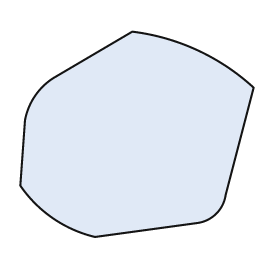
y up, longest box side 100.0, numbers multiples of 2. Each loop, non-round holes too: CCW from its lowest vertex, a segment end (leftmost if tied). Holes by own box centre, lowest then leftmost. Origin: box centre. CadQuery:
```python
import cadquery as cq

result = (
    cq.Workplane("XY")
    .moveTo(-18.0, -44.0)
    .lineTo(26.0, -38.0)
    .threePointArc((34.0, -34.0), (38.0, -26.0))
    .lineTo(50.0, 20.0)
    .threePointArc((26.0, 36.0), (-2.0, 44.0))
    .lineTo(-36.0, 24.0)
    .threePointArc((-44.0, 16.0), (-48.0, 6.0))
    .lineTo(-50.0, -22.0)
    .threePointArc((-36.0, -36.0), (-18.0, -44.0))
    .close()
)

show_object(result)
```